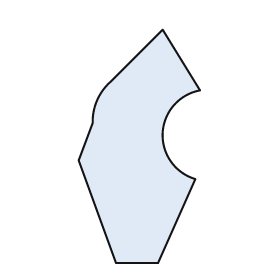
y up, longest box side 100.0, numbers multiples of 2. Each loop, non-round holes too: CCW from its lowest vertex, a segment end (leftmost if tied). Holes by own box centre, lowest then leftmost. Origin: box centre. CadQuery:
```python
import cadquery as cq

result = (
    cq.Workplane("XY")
    .moveTo(-10.0, -50.0)
    .lineTo(8.0, -50.0)
    .lineTo(24.0, -14.0)
    .threePointArc((10.0, 6.0), (26.0, 24.0))
    .lineTo(10.0, 50.0)
    .lineTo(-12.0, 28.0)
    .threePointArc((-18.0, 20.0), (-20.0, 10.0))
    .lineTo(-26.0, -6.0)
    .close()
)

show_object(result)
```